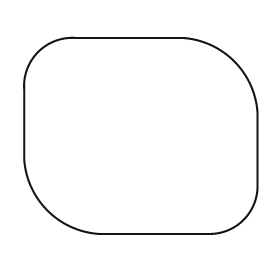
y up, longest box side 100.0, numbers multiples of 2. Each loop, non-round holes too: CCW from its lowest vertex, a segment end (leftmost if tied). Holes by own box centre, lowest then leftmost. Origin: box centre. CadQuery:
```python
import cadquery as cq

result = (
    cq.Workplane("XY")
    .moveTo(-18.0, -42.0)
    .lineTo(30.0, -42.0)
    .threePointArc((44.0, -36.0), (50.0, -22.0))
    .lineTo(50.0, 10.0)
    .threePointArc((40.0, 32.0), (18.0, 42.0))
    .lineTo(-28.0, 42.0)
    .threePointArc((-44.0, 36.0), (-50.0, 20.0))
    .lineTo(-50.0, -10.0)
    .threePointArc((-40.0, -32.0), (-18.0, -42.0))
    .close()
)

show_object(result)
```